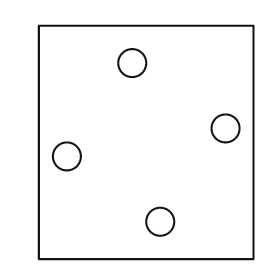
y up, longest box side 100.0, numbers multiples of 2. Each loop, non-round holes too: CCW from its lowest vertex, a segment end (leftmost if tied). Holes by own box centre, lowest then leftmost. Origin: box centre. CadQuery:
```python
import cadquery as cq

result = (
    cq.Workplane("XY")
    .moveTo(-46.0, -50.0)
    .lineTo(46.0, -50.0)
    .lineTo(46.0, 50.0)
    .lineTo(-46.0, 50.0)
    .close()
    .moveTo(6.0, -34.0)
    .circle(6.0)
    .moveTo(-34.0, -6.0)
    .circle(6.0)
    .moveTo(34.0, 6.0)
    .circle(6.0)
    .moveTo(-6.0, 34.0)
    .circle(6.0)
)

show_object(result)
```